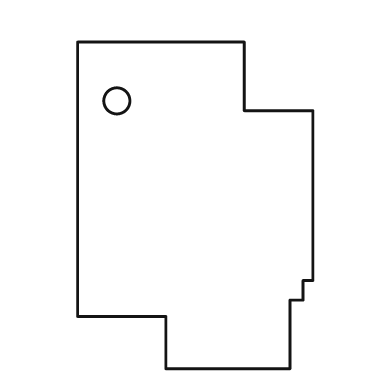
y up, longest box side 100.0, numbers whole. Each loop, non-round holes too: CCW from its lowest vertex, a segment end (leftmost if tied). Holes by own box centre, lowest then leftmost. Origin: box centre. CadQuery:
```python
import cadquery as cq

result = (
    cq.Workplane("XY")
    .moveTo(-9.0, -50.0)
    .lineTo(29.0, -50.0)
    .lineTo(29.0, -29.0)
    .lineTo(33.0, -29.0)
    .lineTo(33.0, -23.0)
    .lineTo(36.0, -23.0)
    .lineTo(36.0, 29.0)
    .lineTo(15.0, 29.0)
    .lineTo(15.0, 50.0)
    .lineTo(-36.0, 50.0)
    .lineTo(-36.0, -34.0)
    .lineTo(-9.0, -34.0)
    .close()
    .moveTo(-24.0, 32.0)
    .circle(4.0)
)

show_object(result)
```